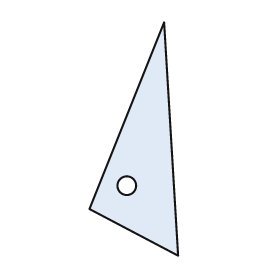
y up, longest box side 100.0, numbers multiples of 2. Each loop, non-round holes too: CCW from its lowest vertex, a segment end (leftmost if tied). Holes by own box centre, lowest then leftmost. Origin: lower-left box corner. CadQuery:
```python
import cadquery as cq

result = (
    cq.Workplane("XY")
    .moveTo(38.0, 0.0)
    .lineTo(32.0, 100.0)
    .lineTo(0.0, 20.0)
    .close()
    .moveTo(16.0, 30.0)
    .circle(4.0)
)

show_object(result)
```